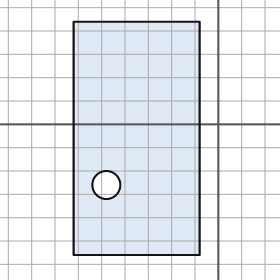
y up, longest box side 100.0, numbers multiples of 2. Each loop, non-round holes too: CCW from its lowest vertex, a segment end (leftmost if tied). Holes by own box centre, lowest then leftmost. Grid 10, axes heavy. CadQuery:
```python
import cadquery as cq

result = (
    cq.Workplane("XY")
    .moveTo(-62.0, -56.0)
    .lineTo(-8.0, -56.0)
    .lineTo(-8.0, 44.0)
    .lineTo(-62.0, 44.0)
    .close()
    .moveTo(-48.0, -26.0)
    .circle(6.0)
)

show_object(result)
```